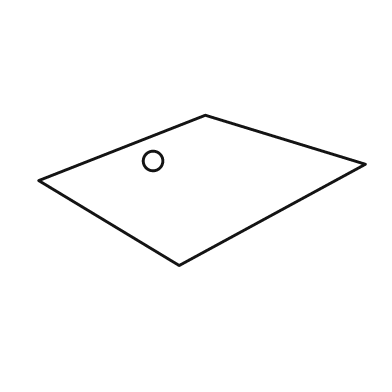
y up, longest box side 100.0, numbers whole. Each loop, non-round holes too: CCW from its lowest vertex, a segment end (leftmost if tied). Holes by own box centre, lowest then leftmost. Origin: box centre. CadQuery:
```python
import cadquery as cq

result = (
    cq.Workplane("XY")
    .moveTo(-7.0, -23.0)
    .lineTo(50.0, 8.0)
    .lineTo(1.0, 23.0)
    .lineTo(-50.0, 3.0)
    .close()
    .moveTo(-15.0, 9.0)
    .circle(3.0)
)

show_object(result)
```